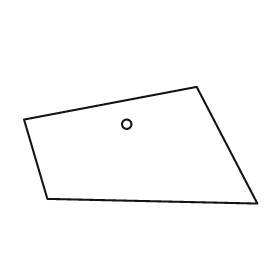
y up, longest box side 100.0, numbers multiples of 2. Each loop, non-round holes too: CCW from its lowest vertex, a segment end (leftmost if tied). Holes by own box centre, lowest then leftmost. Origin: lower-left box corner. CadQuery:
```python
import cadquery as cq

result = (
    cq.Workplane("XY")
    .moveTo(100.0, 0.0)
    .lineTo(74.0, 50.0)
    .lineTo(0.0, 36.0)
    .lineTo(10.0, 2.0)
    .close()
    .moveTo(44.0, 34.0)
    .circle(2.0)
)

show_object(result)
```